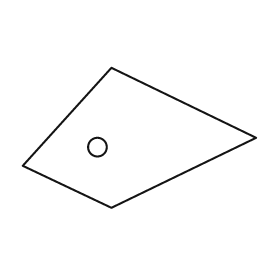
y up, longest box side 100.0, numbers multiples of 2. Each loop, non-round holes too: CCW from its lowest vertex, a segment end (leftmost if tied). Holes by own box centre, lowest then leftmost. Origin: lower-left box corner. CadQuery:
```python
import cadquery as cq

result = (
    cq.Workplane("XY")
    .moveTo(38.0, 0.0)
    .lineTo(100.0, 30.0)
    .lineTo(38.0, 60.0)
    .lineTo(0.0, 18.0)
    .close()
    .moveTo(32.0, 26.0)
    .circle(4.0)
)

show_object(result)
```